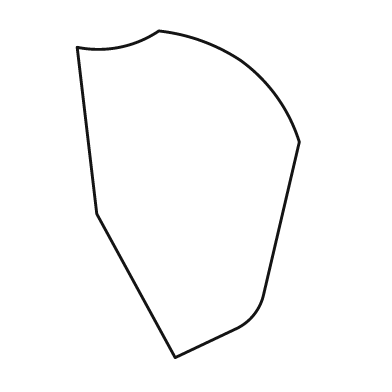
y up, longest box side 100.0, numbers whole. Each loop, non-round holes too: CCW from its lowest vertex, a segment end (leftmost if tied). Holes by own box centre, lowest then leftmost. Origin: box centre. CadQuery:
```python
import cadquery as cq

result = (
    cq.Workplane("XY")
    .moveTo(-4.0, -50.0)
    .lineTo(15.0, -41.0)
    .threePointArc((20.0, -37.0), (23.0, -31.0))
    .lineTo(34.0, 16.0)
    .threePointArc((27.0, 30.0), (16.0, 41.0))
    .threePointArc((4.0, 47.0), (-9.0, 50.0))
    .threePointArc((-21.0, 45.0), (-34.0, 45.0))
    .lineTo(-28.0, -6.0)
    .close()
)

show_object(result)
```